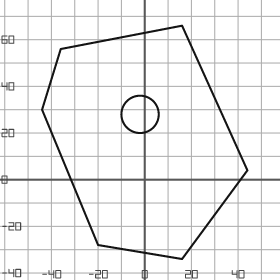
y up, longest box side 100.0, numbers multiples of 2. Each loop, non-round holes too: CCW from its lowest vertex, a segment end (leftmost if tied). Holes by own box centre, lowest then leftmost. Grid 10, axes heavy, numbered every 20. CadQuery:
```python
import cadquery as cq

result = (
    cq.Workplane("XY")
    .moveTo(16.0, -34.0)
    .lineTo(44.0, 4.0)
    .lineTo(16.0, 66.0)
    .lineTo(-36.0, 56.0)
    .lineTo(-44.0, 30.0)
    .lineTo(-20.0, -28.0)
    .close()
    .moveTo(-2.0, 28.0)
    .circle(8.0)
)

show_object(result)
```